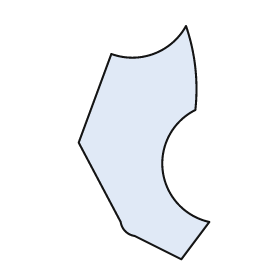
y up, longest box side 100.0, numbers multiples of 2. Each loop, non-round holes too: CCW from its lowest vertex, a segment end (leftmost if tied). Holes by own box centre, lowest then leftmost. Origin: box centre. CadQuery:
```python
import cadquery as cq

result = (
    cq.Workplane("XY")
    .moveTo(16.0, -50.0)
    .lineTo(28.0, -34.0)
    .threePointArc((8.0, -12.0), (22.0, 14.0))
    .threePointArc((22.0, 32.0), (18.0, 50.0))
    .threePointArc((4.0, 38.0), (-14.0, 38.0))
    .lineTo(-28.0, 0.0)
    .lineTo(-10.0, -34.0)
    .threePointArc((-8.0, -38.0), (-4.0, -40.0))
    .close()
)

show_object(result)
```